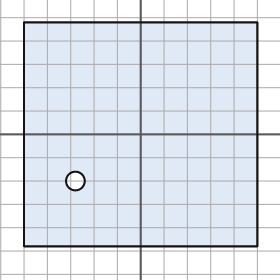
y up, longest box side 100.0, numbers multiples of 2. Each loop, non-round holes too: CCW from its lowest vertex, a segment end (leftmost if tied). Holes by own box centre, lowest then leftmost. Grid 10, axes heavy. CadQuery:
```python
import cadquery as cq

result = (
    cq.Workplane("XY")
    .moveTo(-50.0, -48.0)
    .lineTo(50.0, -48.0)
    .lineTo(50.0, 48.0)
    .lineTo(-50.0, 48.0)
    .close()
    .moveTo(-28.0, -20.0)
    .circle(4.0)
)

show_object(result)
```